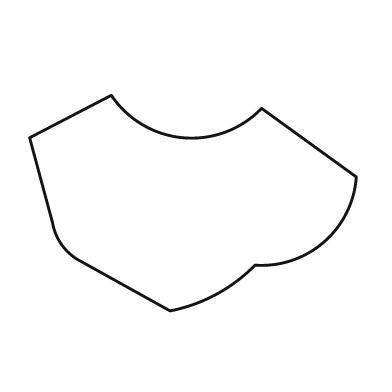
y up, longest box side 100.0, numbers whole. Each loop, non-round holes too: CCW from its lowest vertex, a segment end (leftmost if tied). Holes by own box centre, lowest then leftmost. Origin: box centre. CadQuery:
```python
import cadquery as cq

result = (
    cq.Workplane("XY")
    .moveTo(-7.0, -33.0)
    .threePointArc((7.0, -28.0), (19.0, -19.0))
    .threePointArc((40.0, -12.0), (50.0, 8.0))
    .lineTo(21.0, 29.0)
    .threePointArc((-3.0, 20.0), (-25.0, 33.0))
    .lineTo(-50.0, 20.0)
    .lineTo(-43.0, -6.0)
    .threePointArc((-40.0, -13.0), (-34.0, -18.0))
    .close()
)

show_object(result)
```